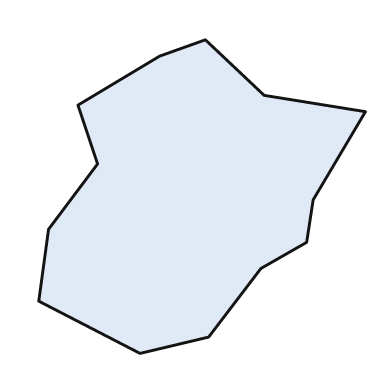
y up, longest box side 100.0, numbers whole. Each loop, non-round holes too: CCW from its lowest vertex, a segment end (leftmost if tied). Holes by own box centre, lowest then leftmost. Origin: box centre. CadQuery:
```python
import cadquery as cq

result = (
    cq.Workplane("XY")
    .moveTo(-19.0, -48.0)
    .lineTo(2.0, -43.0)
    .lineTo(18.0, -22.0)
    .lineTo(32.0, -14.0)
    .lineTo(34.0, -1.0)
    .lineTo(50.0, 26.0)
    .lineTo(19.0, 31.0)
    .lineTo(1.0, 48.0)
    .lineTo(-13.0, 43.0)
    .lineTo(-38.0, 28.0)
    .lineTo(-32.0, 10.0)
    .lineTo(-47.0, -10.0)
    .lineTo(-50.0, -32.0)
    .close()
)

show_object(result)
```